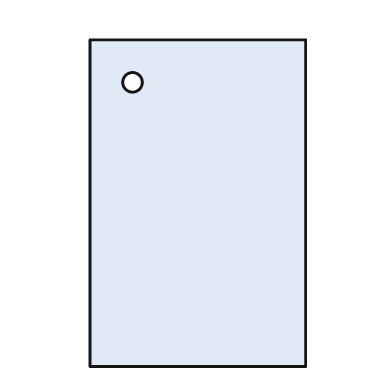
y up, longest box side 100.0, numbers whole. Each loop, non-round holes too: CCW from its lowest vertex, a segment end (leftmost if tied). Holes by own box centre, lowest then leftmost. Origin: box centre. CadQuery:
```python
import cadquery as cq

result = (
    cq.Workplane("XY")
    .moveTo(-33.0, -50.0)
    .lineTo(33.0, -50.0)
    .lineTo(33.0, 50.0)
    .lineTo(-33.0, 50.0)
    .close()
    .moveTo(-20.0, 37.0)
    .circle(3.0)
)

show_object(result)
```